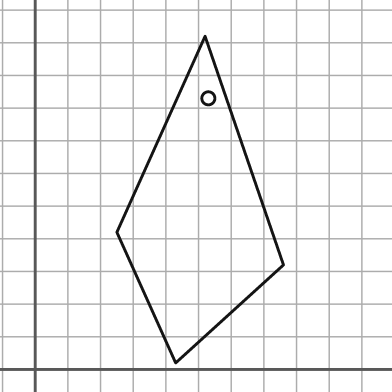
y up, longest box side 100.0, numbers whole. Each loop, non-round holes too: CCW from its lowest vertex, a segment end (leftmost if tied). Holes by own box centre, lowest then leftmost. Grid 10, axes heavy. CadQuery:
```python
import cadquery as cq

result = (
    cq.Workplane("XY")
    .moveTo(43.0, 2.0)
    .lineTo(76.0, 32.0)
    .lineTo(52.0, 102.0)
    .lineTo(25.0, 42.0)
    .close()
    .moveTo(53.0, 83.0)
    .circle(2.0)
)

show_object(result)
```